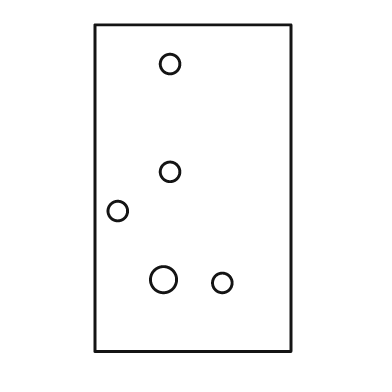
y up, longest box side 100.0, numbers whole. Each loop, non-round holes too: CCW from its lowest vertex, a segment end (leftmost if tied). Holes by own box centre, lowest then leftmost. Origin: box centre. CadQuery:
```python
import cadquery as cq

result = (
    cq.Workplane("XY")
    .moveTo(-30.0, -50.0)
    .lineTo(30.0, -50.0)
    .lineTo(30.0, 50.0)
    .lineTo(-30.0, 50.0)
    .close()
    .moveTo(9.0, -29.0)
    .circle(3.0)
    .moveTo(-9.0, -28.0)
    .circle(4.0)
    .moveTo(-23.0, -7.0)
    .circle(3.0)
    .moveTo(-7.0, 5.0)
    .circle(3.0)
    .moveTo(-7.0, 38.0)
    .circle(3.0)
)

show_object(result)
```